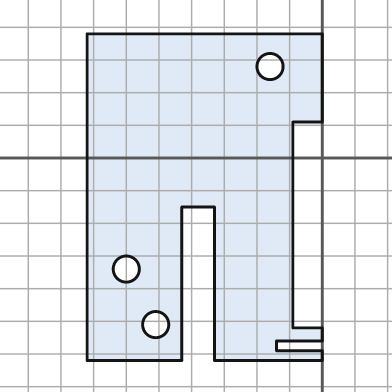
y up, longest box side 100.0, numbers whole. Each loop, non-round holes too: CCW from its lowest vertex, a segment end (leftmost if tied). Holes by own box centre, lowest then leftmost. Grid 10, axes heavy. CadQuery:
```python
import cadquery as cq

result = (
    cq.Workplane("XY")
    .moveTo(-72.0, -62.0)
    .lineTo(-43.0, -62.0)
    .lineTo(-43.0, -15.0)
    .lineTo(-33.0, -15.0)
    .lineTo(-33.0, -62.0)
    .lineTo(0.0, -62.0)
    .lineTo(0.0, -59.0)
    .lineTo(-14.0, -59.0)
    .lineTo(-14.0, -56.0)
    .lineTo(0.0, -56.0)
    .lineTo(0.0, -52.0)
    .lineTo(-9.0, -52.0)
    .lineTo(-9.0, 11.0)
    .lineTo(0.0, 11.0)
    .lineTo(0.0, 38.0)
    .lineTo(-72.0, 38.0)
    .close()
    .moveTo(-51.0, -51.0)
    .circle(4.0)
    .moveTo(-60.0, -34.0)
    .circle(4.0)
    .moveTo(-16.0, 28.0)
    .circle(4.0)
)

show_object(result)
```